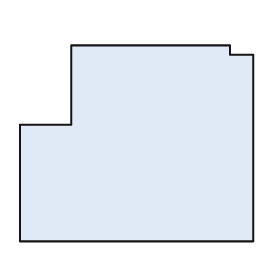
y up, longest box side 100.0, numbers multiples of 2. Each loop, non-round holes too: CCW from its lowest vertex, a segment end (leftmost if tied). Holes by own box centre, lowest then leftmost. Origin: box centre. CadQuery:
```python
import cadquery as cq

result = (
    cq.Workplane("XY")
    .moveTo(-50.0, -42.0)
    .lineTo(50.0, -42.0)
    .lineTo(50.0, 38.0)
    .lineTo(40.0, 38.0)
    .lineTo(40.0, 42.0)
    .lineTo(-28.0, 42.0)
    .lineTo(-28.0, 8.0)
    .lineTo(-50.0, 8.0)
    .close()
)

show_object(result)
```